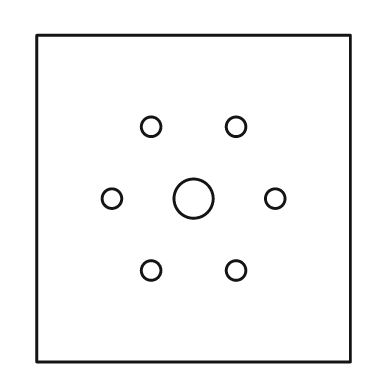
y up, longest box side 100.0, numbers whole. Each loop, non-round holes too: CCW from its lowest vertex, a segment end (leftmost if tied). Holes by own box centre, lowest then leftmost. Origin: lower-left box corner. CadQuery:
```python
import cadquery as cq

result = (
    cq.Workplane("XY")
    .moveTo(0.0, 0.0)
    .lineTo(96.0, 0.0)
    .lineTo(96.0, 100.0)
    .lineTo(0.0, 100.0)
    .close()
    .moveTo(35.0, 28.0)
    .circle(3.0)
    .moveTo(61.0, 28.0)
    .circle(3.0)
    .moveTo(23.0, 50.0)
    .circle(3.0)
    .moveTo(48.0, 50.0)
    .circle(6.0)
    .moveTo(73.0, 50.0)
    .circle(3.0)
    .moveTo(35.0, 72.0)
    .circle(3.0)
    .moveTo(61.0, 72.0)
    .circle(3.0)
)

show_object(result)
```